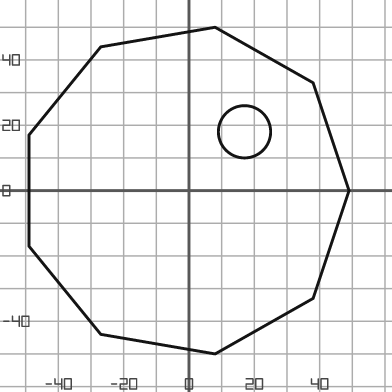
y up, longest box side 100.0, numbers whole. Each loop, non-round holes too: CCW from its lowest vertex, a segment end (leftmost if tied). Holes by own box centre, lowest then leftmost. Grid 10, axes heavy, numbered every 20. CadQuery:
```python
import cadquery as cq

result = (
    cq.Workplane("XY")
    .moveTo(8.0, -50.0)
    .lineTo(38.0, -33.0)
    .lineTo(49.0, 0.0)
    .lineTo(38.0, 33.0)
    .lineTo(8.0, 50.0)
    .lineTo(-27.0, 44.0)
    .lineTo(-49.0, 17.0)
    .lineTo(-49.0, -17.0)
    .lineTo(-27.0, -44.0)
    .close()
    .moveTo(17.0, 18.0)
    .circle(8.0)
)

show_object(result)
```